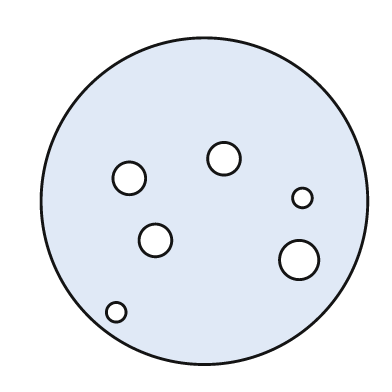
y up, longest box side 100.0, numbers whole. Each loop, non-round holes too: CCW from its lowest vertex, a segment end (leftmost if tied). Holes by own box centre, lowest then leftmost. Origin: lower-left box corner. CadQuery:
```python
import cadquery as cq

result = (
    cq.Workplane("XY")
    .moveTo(50.0, 50.0)
    .circle(50.0)
    .moveTo(23.0, 16.0)
    .circle(3.0)
    .moveTo(79.0, 32.0)
    .circle(6.0)
    .moveTo(35.0, 38.0)
    .circle(5.0)
    .moveTo(80.0, 51.0)
    .circle(3.0)
    .moveTo(27.0, 57.0)
    .circle(5.0)
    .moveTo(56.0, 63.0)
    .circle(5.0)
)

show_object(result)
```